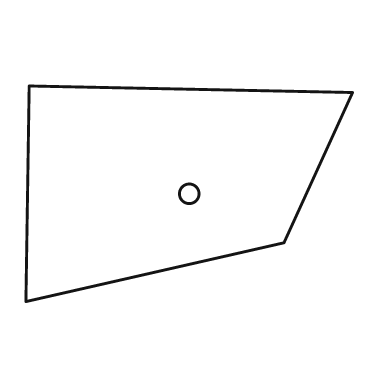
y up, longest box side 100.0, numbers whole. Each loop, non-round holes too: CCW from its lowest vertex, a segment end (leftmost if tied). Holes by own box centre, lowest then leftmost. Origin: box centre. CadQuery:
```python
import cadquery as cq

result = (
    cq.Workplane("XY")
    .moveTo(-50.0, -33.0)
    .lineTo(29.0, -15.0)
    .lineTo(50.0, 31.0)
    .lineTo(-49.0, 33.0)
    .close()
    .moveTo(0.0, 0.0)
    .circle(3.0)
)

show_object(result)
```